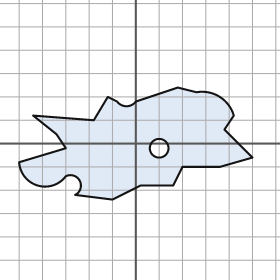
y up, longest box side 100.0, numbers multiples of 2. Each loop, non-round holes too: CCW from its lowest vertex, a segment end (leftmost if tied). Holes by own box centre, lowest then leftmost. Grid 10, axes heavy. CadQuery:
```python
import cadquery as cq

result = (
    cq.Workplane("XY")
    .moveTo(-10.0, -24.0)
    .lineTo(2.0, -18.0)
    .lineTo(16.0, -18.0)
    .lineTo(20.0, -10.0)
    .lineTo(36.0, -10.0)
    .lineTo(50.0, -6.0)
    .lineTo(38.0, 6.0)
    .lineTo(42.0, 12.0)
    .threePointArc((36.0, 20.0), (26.0, 22.0))
    .lineTo(18.0, 24.0)
    .lineTo(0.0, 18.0)
    .threePointArc((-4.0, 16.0), (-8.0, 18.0))
    .lineTo(-12.0, 20.0)
    .lineTo(-18.0, 10.0)
    .lineTo(-44.0, 12.0)
    .lineTo(-34.0, 4.0)
    .lineTo(-30.0, -2.0)
    .lineTo(-50.0, -8.0)
    .threePointArc((-42.0, -18.0), (-30.0, -14.0))
    .threePointArc((-24.0, -16.0), (-26.0, -22.0))
    .close()
    .moveTo(10.0, -2.0)
    .circle(4.0)
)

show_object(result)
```